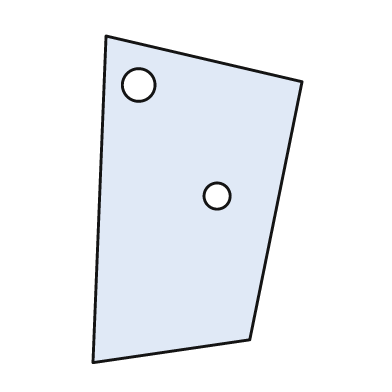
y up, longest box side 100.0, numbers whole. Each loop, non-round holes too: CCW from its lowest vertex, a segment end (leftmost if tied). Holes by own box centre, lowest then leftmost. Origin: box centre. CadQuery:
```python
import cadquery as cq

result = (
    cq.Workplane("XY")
    .moveTo(-32.0, -50.0)
    .lineTo(16.0, -43.0)
    .lineTo(32.0, 36.0)
    .lineTo(-28.0, 50.0)
    .close()
    .moveTo(6.0, 1.0)
    .circle(4.0)
    .moveTo(-18.0, 35.0)
    .circle(5.0)
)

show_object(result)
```